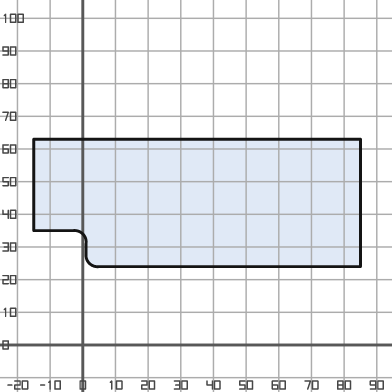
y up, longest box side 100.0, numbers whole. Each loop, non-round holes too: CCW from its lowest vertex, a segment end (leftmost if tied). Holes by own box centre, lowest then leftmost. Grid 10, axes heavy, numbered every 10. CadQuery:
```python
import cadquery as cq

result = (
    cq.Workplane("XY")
    .moveTo(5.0, 24.0)
    .lineTo(85.0, 24.0)
    .lineTo(85.0, 63.0)
    .lineTo(-15.0, 63.0)
    .lineTo(-15.0, 35.0)
    .lineTo(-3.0, 35.0)
    .threePointArc((0.0, 34.0), (1.0, 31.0))
    .lineTo(1.0, 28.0)
    .threePointArc((2.0, 25.0), (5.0, 24.0))
    .close()
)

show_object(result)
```